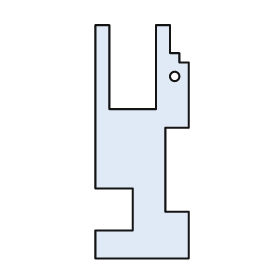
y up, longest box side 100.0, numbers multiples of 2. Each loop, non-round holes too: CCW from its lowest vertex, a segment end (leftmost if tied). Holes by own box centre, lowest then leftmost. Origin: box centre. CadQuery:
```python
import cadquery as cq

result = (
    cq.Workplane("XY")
    .moveTo(-20.0, -50.0)
    .lineTo(20.0, -50.0)
    .lineTo(20.0, -30.0)
    .lineTo(10.0, -30.0)
    .lineTo(10.0, 6.0)
    .lineTo(20.0, 6.0)
    .lineTo(20.0, 34.0)
    .lineTo(16.0, 34.0)
    .lineTo(16.0, 38.0)
    .lineTo(12.0, 38.0)
    .lineTo(12.0, 50.0)
    .lineTo(6.0, 50.0)
    .lineTo(6.0, 14.0)
    .lineTo(-14.0, 14.0)
    .lineTo(-14.0, 50.0)
    .lineTo(-20.0, 50.0)
    .lineTo(-20.0, -20.0)
    .lineTo(-4.0, -20.0)
    .lineTo(-4.0, -38.0)
    .lineTo(-20.0, -38.0)
    .close()
    .moveTo(14.0, 28.0)
    .circle(2.0)
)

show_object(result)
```